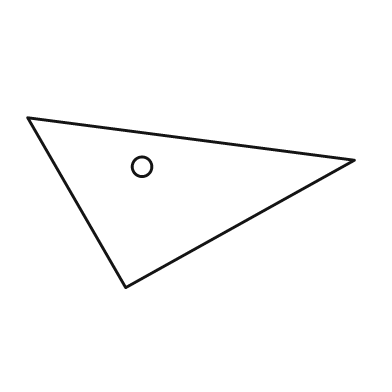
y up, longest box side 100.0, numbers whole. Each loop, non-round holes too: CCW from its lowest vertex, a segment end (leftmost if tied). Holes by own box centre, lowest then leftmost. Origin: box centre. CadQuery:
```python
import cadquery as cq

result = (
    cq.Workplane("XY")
    .moveTo(-20.0, -26.0)
    .lineTo(50.0, 13.0)
    .lineTo(-50.0, 26.0)
    .close()
    .moveTo(-15.0, 11.0)
    .circle(3.0)
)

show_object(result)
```